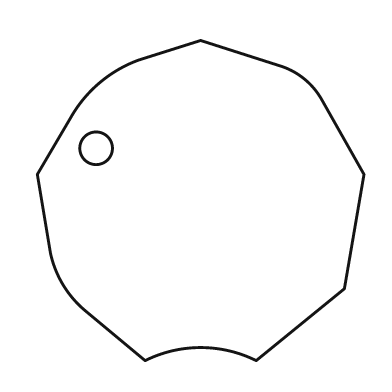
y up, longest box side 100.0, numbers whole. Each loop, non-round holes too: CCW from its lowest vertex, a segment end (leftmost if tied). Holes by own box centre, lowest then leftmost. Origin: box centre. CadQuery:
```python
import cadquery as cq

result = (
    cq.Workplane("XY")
    .moveTo(-17.0, -49.0)
    .threePointArc((0.0, -45.0), (17.0, -49.0))
    .lineTo(44.0, -27.0)
    .lineTo(50.0, 8.0)
    .lineTo(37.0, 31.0)
    .threePointArc((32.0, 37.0), (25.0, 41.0))
    .lineTo(0.0, 49.0)
    .lineTo(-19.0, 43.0)
    .threePointArc((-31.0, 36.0), (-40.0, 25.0))
    .lineTo(-50.0, 8.0)
    .lineTo(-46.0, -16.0)
    .threePointArc((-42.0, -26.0), (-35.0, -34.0))
    .close()
    .moveTo(-32.0, 16.0)
    .circle(5.0)
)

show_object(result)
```